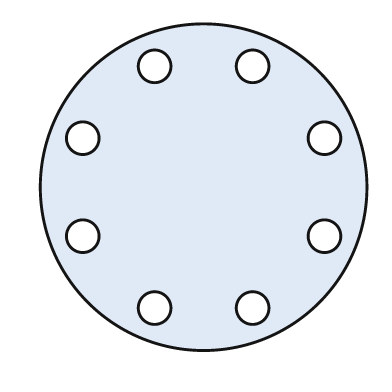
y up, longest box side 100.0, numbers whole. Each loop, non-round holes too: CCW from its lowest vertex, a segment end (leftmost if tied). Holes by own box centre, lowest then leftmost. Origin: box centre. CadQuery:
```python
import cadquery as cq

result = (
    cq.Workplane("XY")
    .moveTo(0.0, 0.0)
    .circle(50.0)
    .moveTo(-15.0, -37.0)
    .circle(5.0)
    .moveTo(15.0, -37.0)
    .circle(5.0)
    .moveTo(-37.0, -15.0)
    .circle(5.0)
    .moveTo(37.0, -15.0)
    .circle(5.0)
    .moveTo(-37.0, 15.0)
    .circle(5.0)
    .moveTo(37.0, 15.0)
    .circle(5.0)
    .moveTo(-15.0, 37.0)
    .circle(5.0)
    .moveTo(15.0, 37.0)
    .circle(5.0)
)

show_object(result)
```